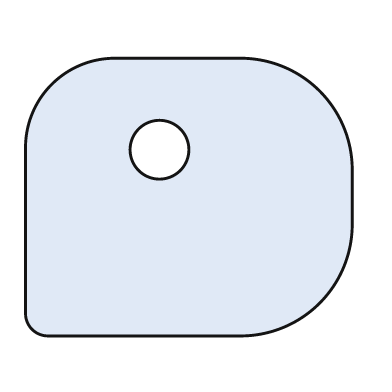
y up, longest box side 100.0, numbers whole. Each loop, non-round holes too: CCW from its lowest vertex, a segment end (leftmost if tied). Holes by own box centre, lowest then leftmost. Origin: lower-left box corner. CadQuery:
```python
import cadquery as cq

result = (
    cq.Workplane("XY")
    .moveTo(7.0, 0.0)
    .lineTo(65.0, 0.0)
    .threePointArc((90.0, 10.0), (100.0, 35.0))
    .lineTo(100.0, 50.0)
    .threePointArc((90.0, 75.0), (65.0, 85.0))
    .lineTo(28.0, 85.0)
    .threePointArc((8.0, 77.0), (0.0, 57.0))
    .lineTo(0.0, 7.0)
    .threePointArc((2.0, 2.0), (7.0, 0.0))
    .close()
    .moveTo(41.0, 57.0)
    .circle(9.0)
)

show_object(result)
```